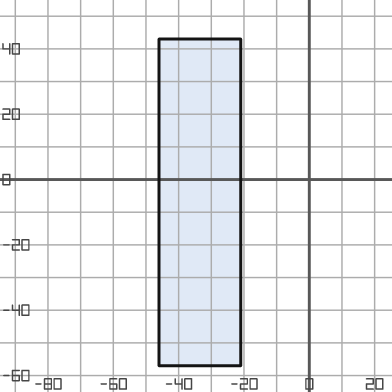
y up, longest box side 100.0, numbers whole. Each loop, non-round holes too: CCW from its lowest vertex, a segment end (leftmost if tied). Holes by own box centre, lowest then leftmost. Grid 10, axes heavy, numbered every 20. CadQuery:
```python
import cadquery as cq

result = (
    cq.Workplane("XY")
    .moveTo(-46.0, -57.0)
    .lineTo(-21.0, -57.0)
    .lineTo(-21.0, 43.0)
    .lineTo(-46.0, 43.0)
    .close()
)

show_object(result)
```